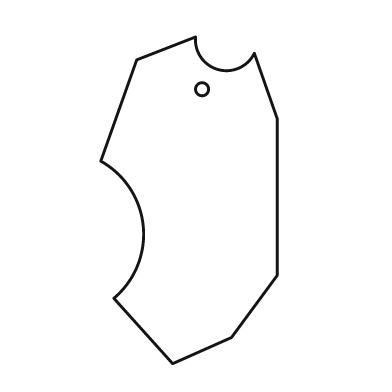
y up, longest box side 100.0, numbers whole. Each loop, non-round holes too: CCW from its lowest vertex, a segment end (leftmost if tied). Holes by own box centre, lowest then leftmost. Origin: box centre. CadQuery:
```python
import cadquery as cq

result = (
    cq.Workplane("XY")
    .moveTo(-5.0, -50.0)
    .lineTo(13.0, -42.0)
    .lineTo(27.0, -23.0)
    .lineTo(27.0, 25.0)
    .lineTo(20.0, 45.0)
    .threePointArc((9.0, 40.0), (2.0, 50.0))
    .lineTo(-16.0, 43.0)
    .lineTo(-27.0, 12.0)
    .threePointArc((-14.0, -8.0), (-23.0, -30.0))
    .close()
    .moveTo(4.0, 34.0)
    .circle(2.0)
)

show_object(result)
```